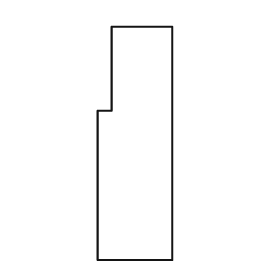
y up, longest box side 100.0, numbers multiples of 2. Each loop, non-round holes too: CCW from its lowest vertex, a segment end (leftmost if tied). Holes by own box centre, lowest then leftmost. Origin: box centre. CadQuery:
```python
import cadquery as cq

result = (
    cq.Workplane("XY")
    .moveTo(-16.0, -50.0)
    .lineTo(16.0, -50.0)
    .lineTo(16.0, 50.0)
    .lineTo(-10.0, 50.0)
    .lineTo(-10.0, 14.0)
    .lineTo(-16.0, 14.0)
    .close()
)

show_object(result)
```